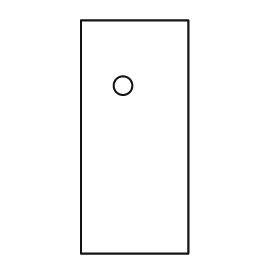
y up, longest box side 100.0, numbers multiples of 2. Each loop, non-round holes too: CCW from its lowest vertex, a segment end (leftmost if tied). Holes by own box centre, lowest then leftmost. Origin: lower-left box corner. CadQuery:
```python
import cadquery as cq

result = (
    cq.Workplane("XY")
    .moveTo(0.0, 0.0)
    .lineTo(46.0, 0.0)
    .lineTo(46.0, 100.0)
    .lineTo(0.0, 100.0)
    .close()
    .moveTo(18.0, 72.0)
    .circle(4.0)
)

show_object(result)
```